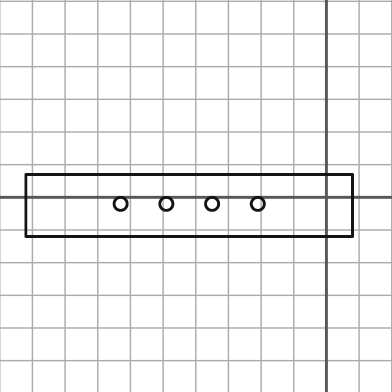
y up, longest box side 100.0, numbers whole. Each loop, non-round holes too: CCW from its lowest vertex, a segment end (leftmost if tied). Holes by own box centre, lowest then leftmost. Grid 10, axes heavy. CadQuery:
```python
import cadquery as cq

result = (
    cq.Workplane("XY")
    .moveTo(-92.0, -12.0)
    .lineTo(8.0, -12.0)
    .lineTo(8.0, 7.0)
    .lineTo(-92.0, 7.0)
    .close()
    .moveTo(-63.0, -2.0)
    .circle(2.0)
    .moveTo(-49.0, -2.0)
    .circle(2.0)
    .moveTo(-35.0, -2.0)
    .circle(2.0)
    .moveTo(-21.0, -2.0)
    .circle(2.0)
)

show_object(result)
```